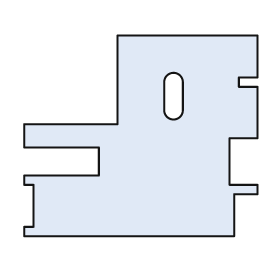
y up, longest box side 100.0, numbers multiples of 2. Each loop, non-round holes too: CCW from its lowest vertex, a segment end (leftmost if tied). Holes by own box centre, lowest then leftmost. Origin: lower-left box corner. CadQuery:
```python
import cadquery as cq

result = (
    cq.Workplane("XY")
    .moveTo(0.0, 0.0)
    .lineTo(90.0, 0.0)
    .lineTo(90.0, 18.0)
    .lineTo(100.0, 18.0)
    .lineTo(100.0, 22.0)
    .lineTo(88.0, 22.0)
    .lineTo(88.0, 42.0)
    .lineTo(100.0, 42.0)
    .lineTo(100.0, 64.0)
    .lineTo(92.0, 64.0)
    .lineTo(92.0, 68.0)
    .lineTo(100.0, 68.0)
    .lineTo(100.0, 86.0)
    .lineTo(40.0, 86.0)
    .lineTo(40.0, 48.0)
    .lineTo(0.0, 48.0)
    .lineTo(0.0, 38.0)
    .lineTo(32.0, 38.0)
    .lineTo(32.0, 26.0)
    .lineTo(0.0, 26.0)
    .lineTo(0.0, 22.0)
    .lineTo(4.0, 22.0)
    .lineTo(4.0, 4.0)
    .lineTo(0.0, 4.0)
    .close()
    .moveTo(60.0, 54.0)
    .threePointArc((64.0, 50.0), (68.0, 54.0))
    .lineTo(68.0, 66.0)
    .threePointArc((64.0, 70.0), (60.0, 66.0))
    .close()
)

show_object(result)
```